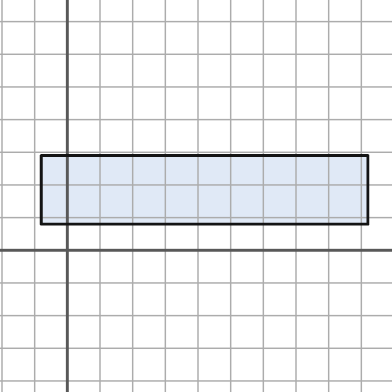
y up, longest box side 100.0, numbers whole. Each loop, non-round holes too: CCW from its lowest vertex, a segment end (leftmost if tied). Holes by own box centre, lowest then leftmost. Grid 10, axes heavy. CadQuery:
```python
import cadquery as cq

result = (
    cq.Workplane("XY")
    .moveTo(-8.0, 8.0)
    .lineTo(92.0, 8.0)
    .lineTo(92.0, 29.0)
    .lineTo(-8.0, 29.0)
    .close()
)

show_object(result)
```